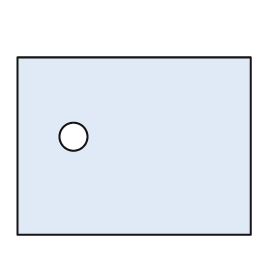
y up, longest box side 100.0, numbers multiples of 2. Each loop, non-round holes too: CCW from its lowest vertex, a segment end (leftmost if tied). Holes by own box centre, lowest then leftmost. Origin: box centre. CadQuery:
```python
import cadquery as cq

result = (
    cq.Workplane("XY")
    .moveTo(-50.0, -38.0)
    .lineTo(50.0, -38.0)
    .lineTo(50.0, 38.0)
    .lineTo(-50.0, 38.0)
    .close()
    .moveTo(-26.0, 4.0)
    .circle(6.0)
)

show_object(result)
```